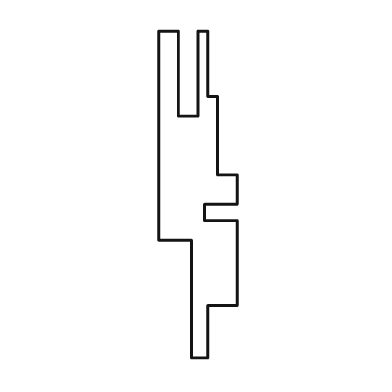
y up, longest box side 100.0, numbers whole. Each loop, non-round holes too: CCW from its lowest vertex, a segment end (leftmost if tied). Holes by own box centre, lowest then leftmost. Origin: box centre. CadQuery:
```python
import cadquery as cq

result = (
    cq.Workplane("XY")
    .moveTo(-2.0, -50.0)
    .lineTo(3.0, -50.0)
    .lineTo(3.0, -34.0)
    .lineTo(12.0, -34.0)
    .lineTo(12.0, -8.0)
    .lineTo(2.0, -8.0)
    .lineTo(2.0, -3.0)
    .lineTo(12.0, -3.0)
    .lineTo(12.0, 6.0)
    .lineTo(6.0, 6.0)
    .lineTo(6.0, 30.0)
    .lineTo(3.0, 30.0)
    .lineTo(3.0, 50.0)
    .lineTo(0.0, 50.0)
    .lineTo(0.0, 24.0)
    .lineTo(-6.0, 24.0)
    .lineTo(-6.0, 50.0)
    .lineTo(-12.0, 50.0)
    .lineTo(-12.0, -14.0)
    .lineTo(-2.0, -14.0)
    .close()
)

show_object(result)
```